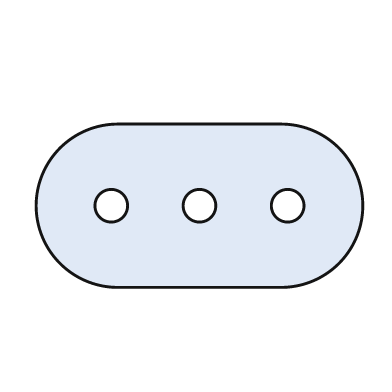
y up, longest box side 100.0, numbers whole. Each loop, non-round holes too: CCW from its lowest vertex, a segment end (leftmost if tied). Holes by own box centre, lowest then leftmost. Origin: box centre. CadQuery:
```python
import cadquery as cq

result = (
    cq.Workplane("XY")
    .moveTo(-25.0, -25.0)
    .lineTo(25.0, -25.0)
    .threePointArc((50.0, 0.0), (25.0, 25.0))
    .lineTo(-25.0, 25.0)
    .threePointArc((-50.0, 0.0), (-25.0, -25.0))
    .close()
    .moveTo(-27.0, 0.0)
    .circle(5.0)
    .moveTo(0.0, 0.0)
    .circle(5.0)
    .moveTo(27.0, 0.0)
    .circle(5.0)
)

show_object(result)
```